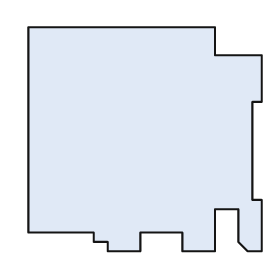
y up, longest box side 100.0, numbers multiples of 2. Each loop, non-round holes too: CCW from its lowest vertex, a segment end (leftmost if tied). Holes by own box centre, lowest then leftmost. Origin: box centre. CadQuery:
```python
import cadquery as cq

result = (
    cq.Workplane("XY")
    .moveTo(-16.0, -48.0)
    .lineTo(-2.0, -48.0)
    .lineTo(-2.0, -40.0)
    .lineTo(16.0, -40.0)
    .lineTo(16.0, -48.0)
    .lineTo(30.0, -48.0)
    .lineTo(30.0, -30.0)
    .lineTo(40.0, -30.0)
    .lineTo(40.0, -44.0)
    .lineTo(44.0, -48.0)
    .lineTo(50.0, -48.0)
    .lineTo(50.0, -26.0)
    .lineTo(46.0, -26.0)
    .lineTo(46.0, 16.0)
    .lineTo(50.0, 16.0)
    .lineTo(50.0, 36.0)
    .lineTo(30.0, 36.0)
    .lineTo(30.0, 48.0)
    .lineTo(-50.0, 48.0)
    .lineTo(-50.0, -40.0)
    .lineTo(-22.0, -40.0)
    .lineTo(-22.0, -44.0)
    .lineTo(-16.0, -44.0)
    .close()
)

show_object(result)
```